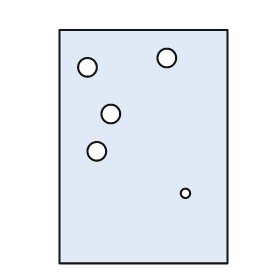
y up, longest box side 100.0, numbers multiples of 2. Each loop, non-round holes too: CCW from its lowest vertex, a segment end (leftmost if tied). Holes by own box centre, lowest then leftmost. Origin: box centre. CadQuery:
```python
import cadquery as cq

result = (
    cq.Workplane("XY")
    .moveTo(-36.0, -50.0)
    .lineTo(36.0, -50.0)
    .lineTo(36.0, 50.0)
    .lineTo(-36.0, 50.0)
    .close()
    .moveTo(18.0, -20.0)
    .circle(2.0)
    .moveTo(-20.0, -2.0)
    .circle(4.0)
    .moveTo(-14.0, 14.0)
    .circle(4.0)
    .moveTo(-24.0, 34.0)
    .circle(4.0)
    .moveTo(10.0, 38.0)
    .circle(4.0)
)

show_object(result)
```